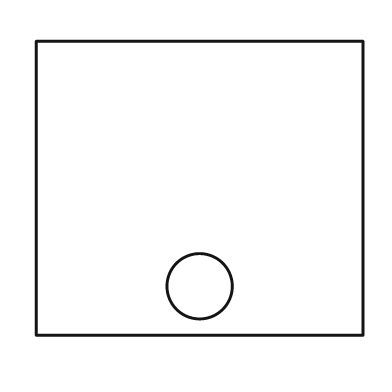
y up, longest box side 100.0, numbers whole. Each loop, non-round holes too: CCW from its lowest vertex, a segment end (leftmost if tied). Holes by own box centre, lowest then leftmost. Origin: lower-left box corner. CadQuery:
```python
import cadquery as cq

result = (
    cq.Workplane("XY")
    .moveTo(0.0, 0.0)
    .lineTo(100.0, 0.0)
    .lineTo(100.0, 90.0)
    .lineTo(0.0, 90.0)
    .close()
    .moveTo(50.0, 15.0)
    .circle(10.0)
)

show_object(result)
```